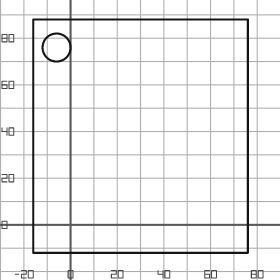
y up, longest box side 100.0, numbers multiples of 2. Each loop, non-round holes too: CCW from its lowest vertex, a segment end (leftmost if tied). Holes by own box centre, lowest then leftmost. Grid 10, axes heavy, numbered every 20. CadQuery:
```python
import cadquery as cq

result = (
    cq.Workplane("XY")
    .moveTo(-16.0, -12.0)
    .lineTo(76.0, -12.0)
    .lineTo(76.0, 88.0)
    .lineTo(-16.0, 88.0)
    .close()
    .moveTo(-6.0, 76.0)
    .circle(6.0)
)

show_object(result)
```